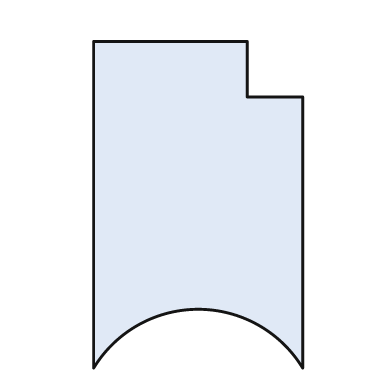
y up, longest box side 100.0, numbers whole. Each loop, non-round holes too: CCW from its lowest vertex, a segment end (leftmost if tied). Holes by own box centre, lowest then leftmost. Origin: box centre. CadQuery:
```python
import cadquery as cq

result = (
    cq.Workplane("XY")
    .moveTo(-32.0, -50.0)
    .threePointArc((0.0, -32.0), (32.0, -50.0))
    .lineTo(32.0, 33.0)
    .lineTo(15.0, 33.0)
    .lineTo(15.0, 50.0)
    .lineTo(-32.0, 50.0)
    .close()
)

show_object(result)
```